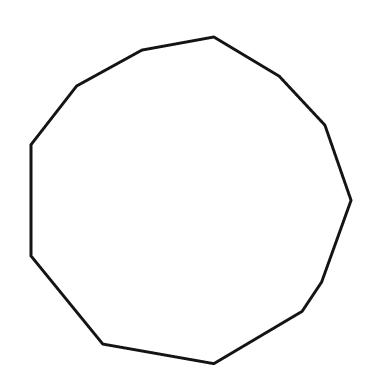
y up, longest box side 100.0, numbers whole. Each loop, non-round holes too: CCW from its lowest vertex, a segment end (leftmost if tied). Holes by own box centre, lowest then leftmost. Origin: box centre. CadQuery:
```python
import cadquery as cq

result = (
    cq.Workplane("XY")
    .moveTo(7.0, -50.0)
    .lineTo(34.0, -34.0)
    .lineTo(40.0, -25.0)
    .lineTo(49.0, 0.0)
    .lineTo(41.0, 23.0)
    .lineTo(27.0, 38.0)
    .lineTo(7.0, 50.0)
    .lineTo(-15.0, 46.0)
    .lineTo(-35.0, 35.0)
    .lineTo(-49.0, 17.0)
    .lineTo(-49.0, -17.0)
    .lineTo(-27.0, -44.0)
    .close()
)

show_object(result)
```